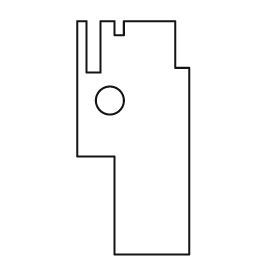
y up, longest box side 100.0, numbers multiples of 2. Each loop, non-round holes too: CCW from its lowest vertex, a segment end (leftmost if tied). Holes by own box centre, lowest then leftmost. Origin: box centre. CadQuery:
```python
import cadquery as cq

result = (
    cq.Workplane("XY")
    .moveTo(-8.0, -50.0)
    .lineTo(24.0, -50.0)
    .lineTo(24.0, 30.0)
    .lineTo(18.0, 30.0)
    .lineTo(18.0, 50.0)
    .lineTo(-4.0, 50.0)
    .lineTo(-4.0, 44.0)
    .lineTo(-8.0, 44.0)
    .lineTo(-8.0, 50.0)
    .lineTo(-14.0, 50.0)
    .lineTo(-14.0, 28.0)
    .lineTo(-20.0, 28.0)
    .lineTo(-20.0, 50.0)
    .lineTo(-24.0, 50.0)
    .lineTo(-24.0, -8.0)
    .lineTo(-8.0, -8.0)
    .close()
    .moveTo(-10.0, 16.0)
    .circle(6.0)
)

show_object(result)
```